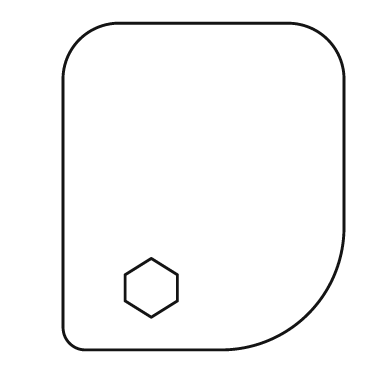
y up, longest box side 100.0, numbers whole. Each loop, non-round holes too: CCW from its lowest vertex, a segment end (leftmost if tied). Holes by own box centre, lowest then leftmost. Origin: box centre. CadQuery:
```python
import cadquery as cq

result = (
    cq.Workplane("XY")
    .moveTo(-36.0, -50.0)
    .lineTo(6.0, -50.0)
    .threePointArc((32.0, -39.0), (43.0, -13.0))
    .lineTo(43.0, 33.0)
    .threePointArc((38.0, 45.0), (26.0, 50.0))
    .lineTo(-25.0, 50.0)
    .threePointArc((-38.0, 45.0), (-43.0, 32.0))
    .lineTo(-43.0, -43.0)
    .threePointArc((-41.0, -48.0), (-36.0, -50.0))
    .close()
    .moveTo(-16.0, -40.0)
    .lineTo(-8.0, -35.0)
    .lineTo(-8.0, -27.0)
    .lineTo(-16.0, -22.0)
    .lineTo(-24.0, -27.0)
    .lineTo(-24.0, -35.0)
    .close()
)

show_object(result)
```